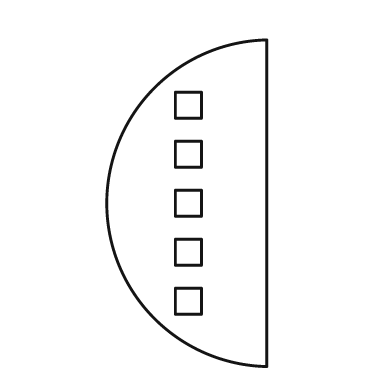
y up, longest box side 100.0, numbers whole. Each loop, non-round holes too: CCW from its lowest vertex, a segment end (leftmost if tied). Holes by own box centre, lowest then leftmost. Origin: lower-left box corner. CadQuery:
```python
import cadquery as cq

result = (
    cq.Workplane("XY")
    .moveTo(49.0, 0.0)
    .lineTo(49.0, 100.0)
    .threePointArc((0.0, 50.0), (49.0, 0.0))
    .close()
    .moveTo(21.0, 16.0)
    .lineTo(29.0, 16.0)
    .lineTo(29.0, 24.0)
    .lineTo(21.0, 24.0)
    .close()
    .moveTo(21.0, 31.0)
    .lineTo(29.0, 31.0)
    .lineTo(29.0, 39.0)
    .lineTo(21.0, 39.0)
    .close()
    .moveTo(21.0, 46.0)
    .lineTo(29.0, 46.0)
    .lineTo(29.0, 54.0)
    .lineTo(21.0, 54.0)
    .close()
    .moveTo(21.0, 61.0)
    .lineTo(29.0, 61.0)
    .lineTo(29.0, 69.0)
    .lineTo(21.0, 69.0)
    .close()
    .moveTo(21.0, 76.0)
    .lineTo(29.0, 76.0)
    .lineTo(29.0, 84.0)
    .lineTo(21.0, 84.0)
    .close()
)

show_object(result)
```